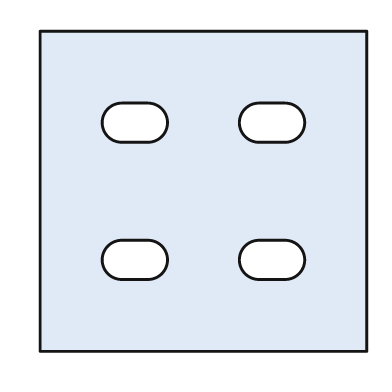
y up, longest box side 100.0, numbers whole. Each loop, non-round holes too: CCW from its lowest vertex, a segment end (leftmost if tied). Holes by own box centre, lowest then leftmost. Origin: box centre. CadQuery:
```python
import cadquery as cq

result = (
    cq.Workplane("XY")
    .moveTo(-50.0, -49.0)
    .lineTo(50.0, -49.0)
    .lineTo(50.0, 49.0)
    .lineTo(-50.0, 49.0)
    .close()
    .moveTo(-25.0, -27.0)
    .lineTo(-17.0, -27.0)
    .threePointArc((-11.0, -21.0), (-17.0, -15.0))
    .lineTo(-25.0, -15.0)
    .threePointArc((-31.0, -21.0), (-25.0, -27.0))
    .close()
    .moveTo(17.0, -27.0)
    .lineTo(25.0, -27.0)
    .threePointArc((31.0, -21.0), (25.0, -15.0))
    .lineTo(17.0, -15.0)
    .threePointArc((11.0, -21.0), (17.0, -27.0))
    .close()
    .moveTo(-25.0, 15.0)
    .lineTo(-17.0, 15.0)
    .threePointArc((-11.0, 21.0), (-17.0, 27.0))
    .lineTo(-25.0, 27.0)
    .threePointArc((-31.0, 21.0), (-25.0, 15.0))
    .close()
    .moveTo(17.0, 15.0)
    .lineTo(25.0, 15.0)
    .threePointArc((31.0, 21.0), (25.0, 27.0))
    .lineTo(17.0, 27.0)
    .threePointArc((11.0, 21.0), (17.0, 15.0))
    .close()
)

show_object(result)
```